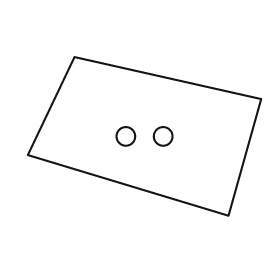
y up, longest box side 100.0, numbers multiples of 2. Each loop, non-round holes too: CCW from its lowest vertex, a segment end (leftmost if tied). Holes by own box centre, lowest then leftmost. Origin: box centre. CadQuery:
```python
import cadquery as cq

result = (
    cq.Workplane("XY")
    .moveTo(36.0, -34.0)
    .lineTo(50.0, 16.0)
    .lineTo(-30.0, 34.0)
    .lineTo(-50.0, -8.0)
    .close()
    .moveTo(-8.0, 0.0)
    .circle(4.0)
    .moveTo(8.0, 0.0)
    .circle(4.0)
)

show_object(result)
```